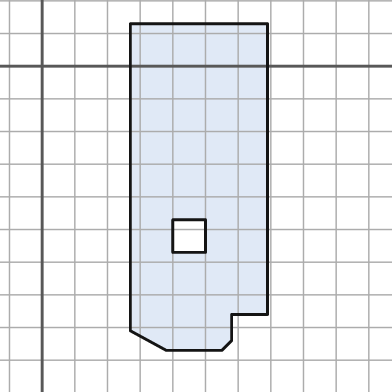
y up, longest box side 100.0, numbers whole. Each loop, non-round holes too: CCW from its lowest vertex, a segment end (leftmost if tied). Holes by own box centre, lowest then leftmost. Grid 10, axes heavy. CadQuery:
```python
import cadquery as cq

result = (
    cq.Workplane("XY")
    .moveTo(38.0, -87.0)
    .lineTo(55.0, -87.0)
    .lineTo(58.0, -84.0)
    .lineTo(58.0, -76.0)
    .lineTo(69.0, -76.0)
    .lineTo(69.0, 13.0)
    .lineTo(27.0, 13.0)
    .lineTo(27.0, -81.0)
    .close()
    .moveTo(40.0, -57.0)
    .lineTo(50.0, -57.0)
    .lineTo(50.0, -47.0)
    .lineTo(40.0, -47.0)
    .close()
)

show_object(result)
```